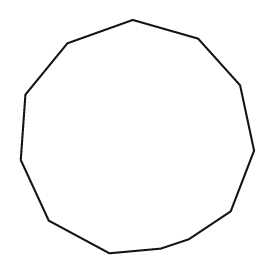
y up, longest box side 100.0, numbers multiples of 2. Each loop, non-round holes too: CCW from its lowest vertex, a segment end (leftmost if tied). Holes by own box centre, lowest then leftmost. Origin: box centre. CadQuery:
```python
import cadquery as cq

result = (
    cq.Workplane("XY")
    .moveTo(-12.0, -50.0)
    .lineTo(10.0, -48.0)
    .lineTo(22.0, -44.0)
    .lineTo(40.0, -32.0)
    .lineTo(50.0, -6.0)
    .lineTo(44.0, 22.0)
    .lineTo(26.0, 42.0)
    .lineTo(-2.0, 50.0)
    .lineTo(-30.0, 40.0)
    .lineTo(-48.0, 18.0)
    .lineTo(-50.0, -10.0)
    .lineTo(-38.0, -36.0)
    .close()
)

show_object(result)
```